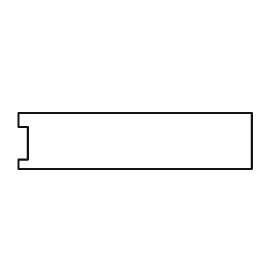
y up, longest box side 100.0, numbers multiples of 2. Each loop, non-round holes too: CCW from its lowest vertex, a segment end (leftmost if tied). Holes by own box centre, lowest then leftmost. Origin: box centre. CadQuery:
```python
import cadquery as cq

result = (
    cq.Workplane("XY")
    .moveTo(-50.0, -12.0)
    .lineTo(50.0, -12.0)
    .lineTo(50.0, 12.0)
    .lineTo(-50.0, 12.0)
    .lineTo(-50.0, 6.0)
    .lineTo(-46.0, 6.0)
    .lineTo(-46.0, -8.0)
    .lineTo(-50.0, -8.0)
    .close()
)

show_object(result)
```